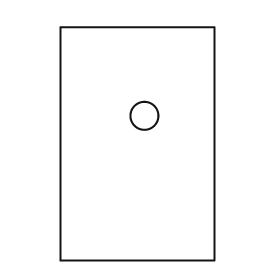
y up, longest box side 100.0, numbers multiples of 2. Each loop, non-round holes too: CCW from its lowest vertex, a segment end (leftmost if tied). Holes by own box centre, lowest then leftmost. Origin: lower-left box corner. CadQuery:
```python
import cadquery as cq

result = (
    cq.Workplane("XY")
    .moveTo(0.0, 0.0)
    .lineTo(66.0, 0.0)
    .lineTo(66.0, 100.0)
    .lineTo(0.0, 100.0)
    .close()
    .moveTo(36.0, 62.0)
    .circle(6.0)
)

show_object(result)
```